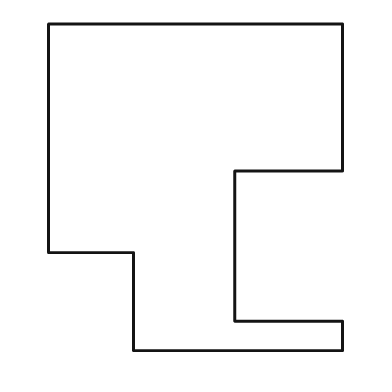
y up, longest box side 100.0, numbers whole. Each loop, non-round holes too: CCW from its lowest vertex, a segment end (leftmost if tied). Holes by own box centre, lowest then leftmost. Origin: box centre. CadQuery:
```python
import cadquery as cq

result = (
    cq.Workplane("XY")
    .moveTo(-19.0, -50.0)
    .lineTo(45.0, -50.0)
    .lineTo(45.0, -41.0)
    .lineTo(12.0, -41.0)
    .lineTo(12.0, 5.0)
    .lineTo(45.0, 5.0)
    .lineTo(45.0, 50.0)
    .lineTo(-45.0, 50.0)
    .lineTo(-45.0, -20.0)
    .lineTo(-19.0, -20.0)
    .close()
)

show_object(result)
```